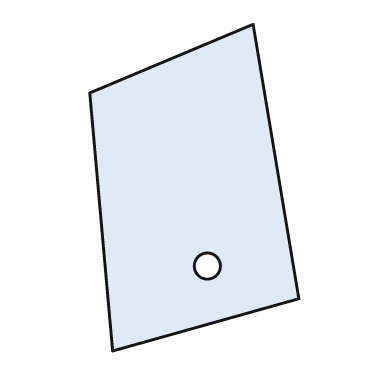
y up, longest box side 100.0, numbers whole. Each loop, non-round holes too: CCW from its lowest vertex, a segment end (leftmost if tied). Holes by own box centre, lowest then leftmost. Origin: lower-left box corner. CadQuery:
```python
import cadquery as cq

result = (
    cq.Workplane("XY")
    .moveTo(7.0, 0.0)
    .lineTo(64.0, 16.0)
    .lineTo(50.0, 100.0)
    .lineTo(0.0, 79.0)
    .close()
    .moveTo(36.0, 26.0)
    .circle(4.0)
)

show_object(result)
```